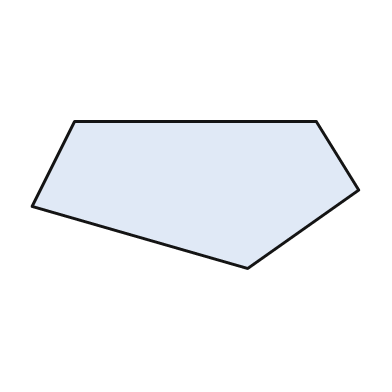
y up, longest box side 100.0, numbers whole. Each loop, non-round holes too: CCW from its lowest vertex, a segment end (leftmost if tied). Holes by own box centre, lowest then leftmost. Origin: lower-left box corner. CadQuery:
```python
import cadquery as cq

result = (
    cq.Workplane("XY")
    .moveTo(66.0, 0.0)
    .lineTo(100.0, 24.0)
    .lineTo(87.0, 45.0)
    .lineTo(13.0, 45.0)
    .lineTo(0.0, 19.0)
    .close()
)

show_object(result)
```